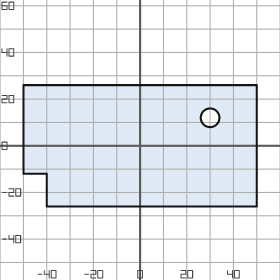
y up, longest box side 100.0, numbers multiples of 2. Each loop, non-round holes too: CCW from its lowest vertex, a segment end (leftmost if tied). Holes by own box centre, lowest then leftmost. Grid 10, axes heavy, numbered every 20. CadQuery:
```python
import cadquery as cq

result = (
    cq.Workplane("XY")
    .moveTo(-40.0, -26.0)
    .lineTo(50.0, -26.0)
    .lineTo(50.0, 26.0)
    .lineTo(-50.0, 26.0)
    .lineTo(-50.0, -12.0)
    .lineTo(-40.0, -12.0)
    .close()
    .moveTo(30.0, 12.0)
    .circle(4.0)
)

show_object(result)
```